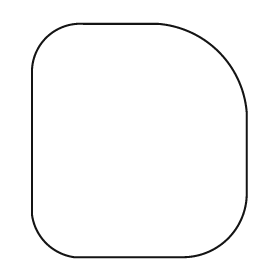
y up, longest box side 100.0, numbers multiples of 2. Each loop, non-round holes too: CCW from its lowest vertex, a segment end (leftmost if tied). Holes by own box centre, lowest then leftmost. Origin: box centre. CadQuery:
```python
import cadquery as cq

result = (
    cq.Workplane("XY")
    .moveTo(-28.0, -50.0)
    .lineTo(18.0, -50.0)
    .threePointArc((38.0, -42.0), (46.0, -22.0))
    .lineTo(46.0, 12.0)
    .threePointArc((34.0, 38.0), (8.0, 50.0))
    .lineTo(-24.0, 50.0)
    .threePointArc((-40.0, 44.0), (-46.0, 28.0))
    .lineTo(-46.0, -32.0)
    .threePointArc((-40.0, -44.0), (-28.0, -50.0))
    .close()
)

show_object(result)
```